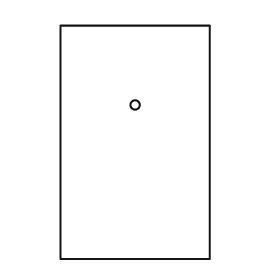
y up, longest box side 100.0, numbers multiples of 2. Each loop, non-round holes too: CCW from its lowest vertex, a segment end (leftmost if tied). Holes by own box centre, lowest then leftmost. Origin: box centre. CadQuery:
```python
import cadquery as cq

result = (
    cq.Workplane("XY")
    .moveTo(-32.0, -50.0)
    .lineTo(32.0, -50.0)
    .lineTo(32.0, 50.0)
    .lineTo(-32.0, 50.0)
    .close()
    .moveTo(0.0, 16.0)
    .circle(2.0)
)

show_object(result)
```